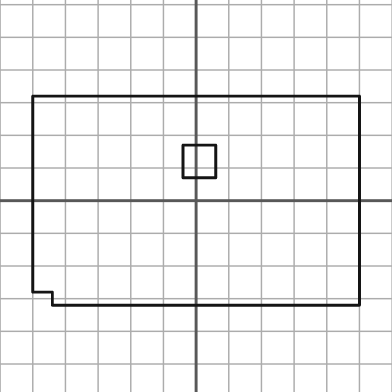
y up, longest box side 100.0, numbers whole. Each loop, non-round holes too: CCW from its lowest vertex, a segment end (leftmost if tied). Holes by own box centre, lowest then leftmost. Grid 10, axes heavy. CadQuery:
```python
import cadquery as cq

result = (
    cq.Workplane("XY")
    .moveTo(-44.0, -32.0)
    .lineTo(50.0, -32.0)
    .lineTo(50.0, 32.0)
    .lineTo(-50.0, 32.0)
    .lineTo(-50.0, -28.0)
    .lineTo(-44.0, -28.0)
    .close()
    .moveTo(-4.0, 7.0)
    .lineTo(6.0, 7.0)
    .lineTo(6.0, 17.0)
    .lineTo(-4.0, 17.0)
    .close()
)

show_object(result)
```